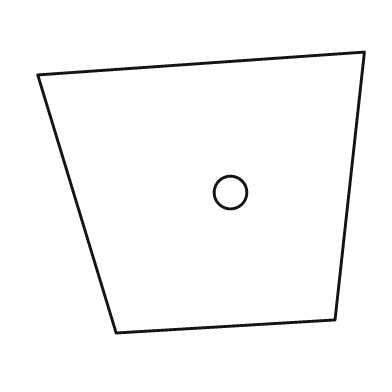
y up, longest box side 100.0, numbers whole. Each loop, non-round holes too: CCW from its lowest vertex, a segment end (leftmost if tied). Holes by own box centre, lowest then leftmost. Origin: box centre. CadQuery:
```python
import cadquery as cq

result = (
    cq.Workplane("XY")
    .moveTo(-26.0, -43.0)
    .lineTo(41.0, -39.0)
    .lineTo(50.0, 43.0)
    .lineTo(-50.0, 36.0)
    .close()
    .moveTo(9.0, 0.0)
    .circle(5.0)
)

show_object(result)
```